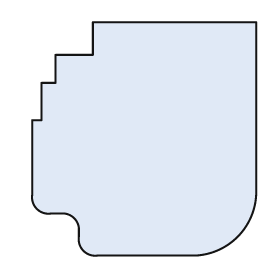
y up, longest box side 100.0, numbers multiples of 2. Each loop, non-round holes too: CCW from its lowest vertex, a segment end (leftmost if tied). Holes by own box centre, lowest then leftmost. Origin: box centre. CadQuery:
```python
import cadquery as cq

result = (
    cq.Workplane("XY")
    .moveTo(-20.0, -50.0)
    .lineTo(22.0, -50.0)
    .threePointArc((40.0, -42.0), (48.0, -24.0))
    .lineTo(48.0, 50.0)
    .lineTo(-22.0, 50.0)
    .lineTo(-22.0, 36.0)
    .lineTo(-38.0, 36.0)
    .lineTo(-38.0, 24.0)
    .lineTo(-44.0, 24.0)
    .lineTo(-44.0, 8.0)
    .lineTo(-48.0, 8.0)
    .lineTo(-48.0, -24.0)
    .threePointArc((-46.0, -30.0), (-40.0, -32.0))
    .lineTo(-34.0, -32.0)
    .threePointArc((-30.0, -34.0), (-28.0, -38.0))
    .lineTo(-28.0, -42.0)
    .threePointArc((-26.0, -48.0), (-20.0, -50.0))
    .close()
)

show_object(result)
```